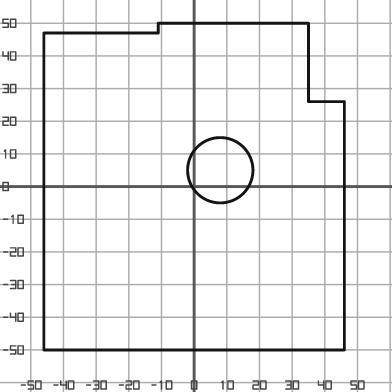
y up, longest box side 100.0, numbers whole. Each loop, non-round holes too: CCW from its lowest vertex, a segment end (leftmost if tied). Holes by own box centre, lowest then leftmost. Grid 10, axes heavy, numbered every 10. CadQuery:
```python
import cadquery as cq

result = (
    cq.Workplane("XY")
    .moveTo(-46.0, -50.0)
    .lineTo(46.0, -50.0)
    .lineTo(46.0, 26.0)
    .lineTo(35.0, 26.0)
    .lineTo(35.0, 50.0)
    .lineTo(-11.0, 50.0)
    .lineTo(-11.0, 47.0)
    .lineTo(-46.0, 47.0)
    .close()
    .moveTo(8.0, 5.0)
    .circle(10.0)
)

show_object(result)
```